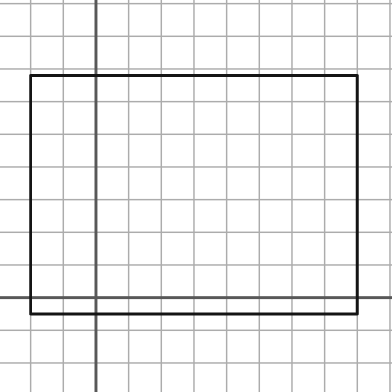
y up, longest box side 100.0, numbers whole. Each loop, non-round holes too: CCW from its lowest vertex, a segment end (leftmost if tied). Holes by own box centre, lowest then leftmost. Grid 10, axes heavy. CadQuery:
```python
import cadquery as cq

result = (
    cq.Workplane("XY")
    .moveTo(-20.0, -5.0)
    .lineTo(80.0, -5.0)
    .lineTo(80.0, 68.0)
    .lineTo(-20.0, 68.0)
    .close()
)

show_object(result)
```